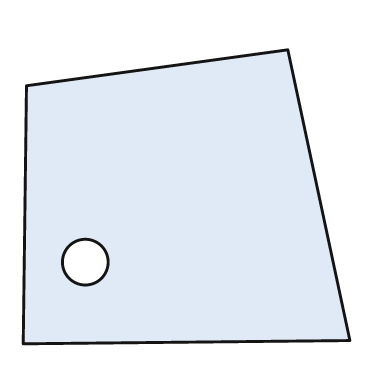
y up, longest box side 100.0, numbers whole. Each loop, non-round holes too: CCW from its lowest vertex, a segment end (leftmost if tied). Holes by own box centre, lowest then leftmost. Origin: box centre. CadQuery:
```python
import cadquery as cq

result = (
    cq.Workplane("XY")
    .moveTo(-50.0, -45.0)
    .lineTo(50.0, -44.0)
    .lineTo(31.0, 45.0)
    .lineTo(-49.0, 34.0)
    .close()
    .moveTo(-31.0, -20.0)
    .circle(7.0)
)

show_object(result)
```